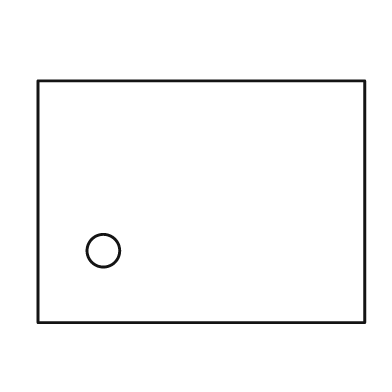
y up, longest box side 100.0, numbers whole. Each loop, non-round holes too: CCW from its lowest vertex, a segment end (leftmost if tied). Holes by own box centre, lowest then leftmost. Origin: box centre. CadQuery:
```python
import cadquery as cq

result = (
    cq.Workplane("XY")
    .moveTo(-50.0, -37.0)
    .lineTo(50.0, -37.0)
    .lineTo(50.0, 37.0)
    .lineTo(-50.0, 37.0)
    .close()
    .moveTo(-30.0, -15.0)
    .circle(5.0)
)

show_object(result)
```